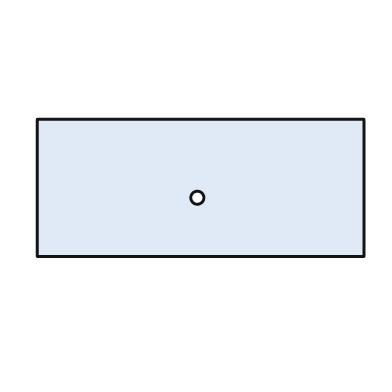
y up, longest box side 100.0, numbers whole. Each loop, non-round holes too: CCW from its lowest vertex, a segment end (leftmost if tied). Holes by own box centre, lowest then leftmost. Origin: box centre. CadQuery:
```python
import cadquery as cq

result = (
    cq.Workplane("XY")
    .moveTo(-50.0, -21.0)
    .lineTo(50.0, -21.0)
    .lineTo(50.0, 21.0)
    .lineTo(-50.0, 21.0)
    .close()
    .moveTo(-1.0, -3.0)
    .circle(2.0)
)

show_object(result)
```